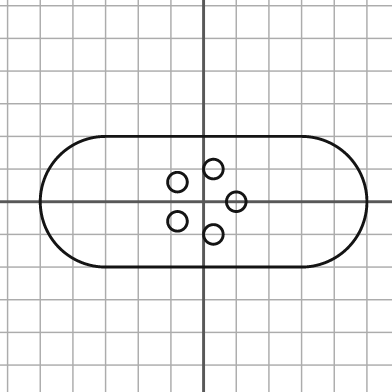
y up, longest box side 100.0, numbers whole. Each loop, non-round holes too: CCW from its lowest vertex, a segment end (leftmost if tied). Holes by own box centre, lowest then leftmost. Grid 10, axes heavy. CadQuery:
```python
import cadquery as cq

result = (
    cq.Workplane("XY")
    .moveTo(-30.0, -20.0)
    .lineTo(30.0, -20.0)
    .threePointArc((50.0, 0.0), (30.0, 20.0))
    .lineTo(-30.0, 20.0)
    .threePointArc((-50.0, 0.0), (-30.0, -20.0))
    .close()
    .moveTo(3.0, -10.0)
    .circle(3.0)
    .moveTo(-8.0, -6.0)
    .circle(3.0)
    .moveTo(10.0, 0.0)
    .circle(3.0)
    .moveTo(-8.0, 6.0)
    .circle(3.0)
    .moveTo(3.0, 10.0)
    .circle(3.0)
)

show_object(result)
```